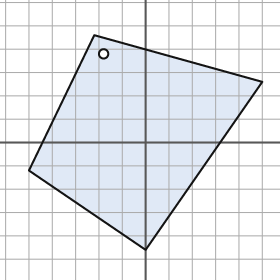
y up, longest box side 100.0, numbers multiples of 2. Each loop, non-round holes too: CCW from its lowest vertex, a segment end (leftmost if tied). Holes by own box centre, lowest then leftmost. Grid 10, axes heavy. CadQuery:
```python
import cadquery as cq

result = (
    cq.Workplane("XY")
    .moveTo(0.0, -46.0)
    .lineTo(50.0, 26.0)
    .lineTo(-22.0, 46.0)
    .lineTo(-50.0, -12.0)
    .close()
    .moveTo(-18.0, 38.0)
    .circle(2.0)
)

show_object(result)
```